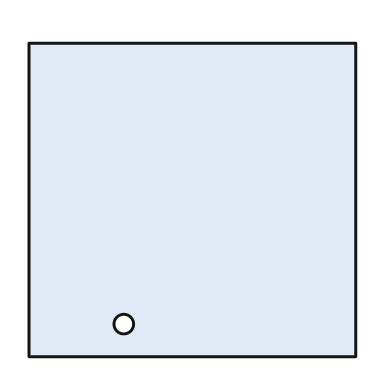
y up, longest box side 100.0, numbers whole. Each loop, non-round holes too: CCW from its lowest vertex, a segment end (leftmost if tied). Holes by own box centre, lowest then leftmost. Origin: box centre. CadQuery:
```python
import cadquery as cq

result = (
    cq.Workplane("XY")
    .moveTo(-50.0, -48.0)
    .lineTo(50.0, -48.0)
    .lineTo(50.0, 48.0)
    .lineTo(-50.0, 48.0)
    .close()
    .moveTo(-21.0, -38.0)
    .circle(3.0)
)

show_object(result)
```